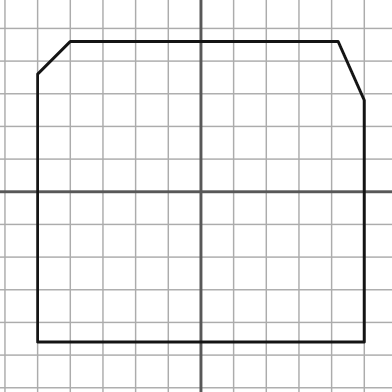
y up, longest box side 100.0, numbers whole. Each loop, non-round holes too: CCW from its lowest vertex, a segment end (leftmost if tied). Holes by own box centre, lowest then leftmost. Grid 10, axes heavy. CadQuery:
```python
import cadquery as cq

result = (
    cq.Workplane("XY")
    .moveTo(-50.0, -46.0)
    .lineTo(50.0, -46.0)
    .lineTo(50.0, 28.0)
    .lineTo(42.0, 46.0)
    .lineTo(-40.0, 46.0)
    .lineTo(-50.0, 36.0)
    .close()
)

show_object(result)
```